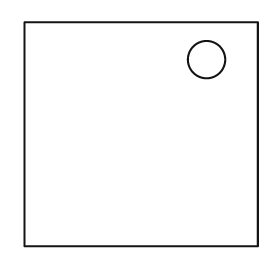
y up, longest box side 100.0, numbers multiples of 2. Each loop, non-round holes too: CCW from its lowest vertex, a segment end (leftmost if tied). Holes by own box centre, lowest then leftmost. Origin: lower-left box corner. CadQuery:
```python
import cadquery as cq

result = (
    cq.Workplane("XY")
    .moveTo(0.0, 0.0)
    .lineTo(100.0, 0.0)
    .lineTo(100.0, 96.0)
    .lineTo(0.0, 96.0)
    .close()
    .moveTo(78.0, 80.0)
    .circle(8.0)
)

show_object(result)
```